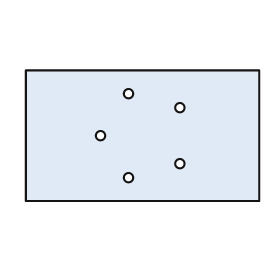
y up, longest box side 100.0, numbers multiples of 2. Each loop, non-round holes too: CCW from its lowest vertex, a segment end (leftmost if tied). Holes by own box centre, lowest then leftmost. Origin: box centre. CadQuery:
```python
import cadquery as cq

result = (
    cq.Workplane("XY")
    .moveTo(-50.0, -28.0)
    .lineTo(50.0, -28.0)
    .lineTo(50.0, 28.0)
    .lineTo(-50.0, 28.0)
    .close()
    .moveTo(-6.0, -18.0)
    .circle(2.0)
    .moveTo(16.0, -12.0)
    .circle(2.0)
    .moveTo(-18.0, 0.0)
    .circle(2.0)
    .moveTo(16.0, 12.0)
    .circle(2.0)
    .moveTo(-6.0, 18.0)
    .circle(2.0)
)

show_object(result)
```